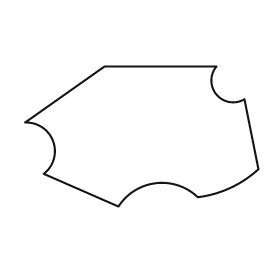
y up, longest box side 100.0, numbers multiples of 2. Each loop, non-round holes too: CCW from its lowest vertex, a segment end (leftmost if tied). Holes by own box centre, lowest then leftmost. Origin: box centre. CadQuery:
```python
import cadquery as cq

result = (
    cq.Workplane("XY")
    .moveTo(-10.0, -30.0)
    .threePointArc((6.0, -20.0), (24.0, -26.0))
    .threePointArc((38.0, -22.0), (50.0, -14.0))
    .lineTo(44.0, 16.0)
    .threePointArc((32.0, 18.0), (32.0, 30.0))
    .lineTo(-16.0, 30.0)
    .lineTo(-50.0, 6.0)
    .threePointArc((-38.0, -2.0), (-42.0, -16.0))
    .close()
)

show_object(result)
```